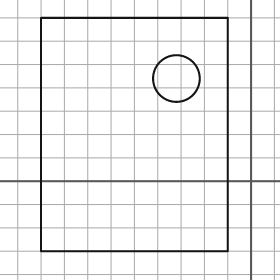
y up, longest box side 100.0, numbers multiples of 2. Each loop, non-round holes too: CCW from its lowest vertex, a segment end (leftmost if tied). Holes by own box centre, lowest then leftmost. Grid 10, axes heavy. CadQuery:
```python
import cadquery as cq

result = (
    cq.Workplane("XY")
    .moveTo(-90.0, -30.0)
    .lineTo(-10.0, -30.0)
    .lineTo(-10.0, 70.0)
    .lineTo(-90.0, 70.0)
    .close()
    .moveTo(-32.0, 44.0)
    .circle(10.0)
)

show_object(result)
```